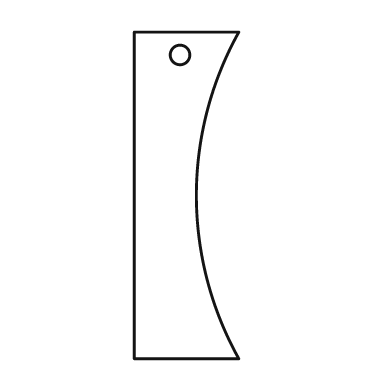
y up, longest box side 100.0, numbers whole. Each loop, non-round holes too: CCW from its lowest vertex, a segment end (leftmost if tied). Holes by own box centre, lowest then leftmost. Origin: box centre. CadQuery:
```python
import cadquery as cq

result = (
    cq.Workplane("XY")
    .moveTo(-16.0, -50.0)
    .lineTo(16.0, -50.0)
    .threePointArc((3.0, 0.0), (16.0, 50.0))
    .lineTo(-16.0, 50.0)
    .close()
    .moveTo(-2.0, 43.0)
    .circle(3.0)
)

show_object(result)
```